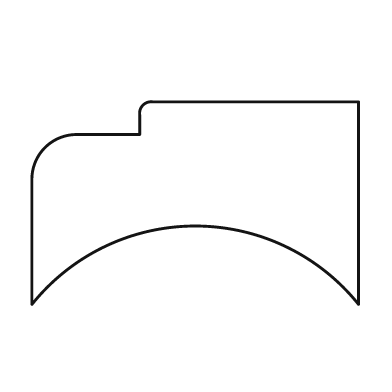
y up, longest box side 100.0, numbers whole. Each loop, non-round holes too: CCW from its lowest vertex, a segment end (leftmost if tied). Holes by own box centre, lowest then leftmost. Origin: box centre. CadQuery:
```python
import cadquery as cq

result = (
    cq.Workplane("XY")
    .moveTo(-50.0, -31.0)
    .threePointArc((0.0, -7.0), (50.0, -31.0))
    .lineTo(50.0, 31.0)
    .lineTo(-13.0, 31.0)
    .threePointArc((-16.0, 30.0), (-17.0, 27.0))
    .lineTo(-17.0, 21.0)
    .lineTo(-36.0, 21.0)
    .threePointArc((-46.0, 17.0), (-50.0, 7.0))
    .close()
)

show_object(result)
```